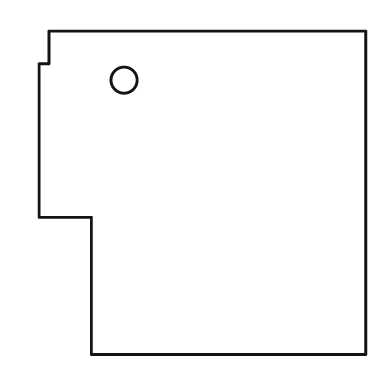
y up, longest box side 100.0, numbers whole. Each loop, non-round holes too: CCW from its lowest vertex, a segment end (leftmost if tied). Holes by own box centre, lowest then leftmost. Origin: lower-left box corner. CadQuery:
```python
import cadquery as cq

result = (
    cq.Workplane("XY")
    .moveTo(16.0, 0.0)
    .lineTo(100.0, 0.0)
    .lineTo(100.0, 99.0)
    .lineTo(3.0, 99.0)
    .lineTo(3.0, 89.0)
    .lineTo(0.0, 89.0)
    .lineTo(0.0, 42.0)
    .lineTo(16.0, 42.0)
    .close()
    .moveTo(26.0, 84.0)
    .circle(4.0)
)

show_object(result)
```